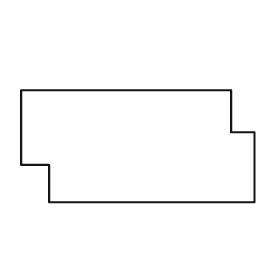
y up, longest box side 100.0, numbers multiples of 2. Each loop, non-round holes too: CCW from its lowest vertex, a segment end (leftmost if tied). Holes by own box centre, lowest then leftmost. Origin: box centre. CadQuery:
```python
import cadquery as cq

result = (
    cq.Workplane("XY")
    .moveTo(-38.0, -24.0)
    .lineTo(50.0, -24.0)
    .lineTo(50.0, 6.0)
    .lineTo(40.0, 6.0)
    .lineTo(40.0, 24.0)
    .lineTo(-50.0, 24.0)
    .lineTo(-50.0, -8.0)
    .lineTo(-38.0, -8.0)
    .close()
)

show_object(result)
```